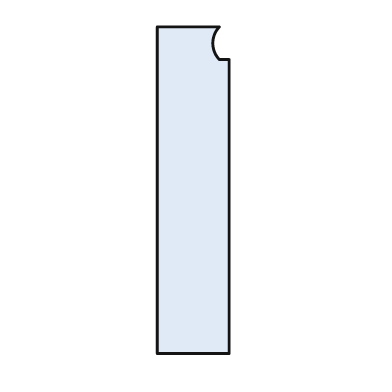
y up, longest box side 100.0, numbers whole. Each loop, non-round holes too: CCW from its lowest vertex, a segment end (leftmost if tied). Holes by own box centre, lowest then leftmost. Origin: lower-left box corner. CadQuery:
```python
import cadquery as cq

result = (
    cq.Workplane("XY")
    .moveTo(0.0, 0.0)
    .lineTo(22.0, 0.0)
    .lineTo(22.0, 90.0)
    .lineTo(19.0, 90.0)
    .threePointArc((17.0, 95.0), (19.0, 100.0))
    .lineTo(0.0, 100.0)
    .close()
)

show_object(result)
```